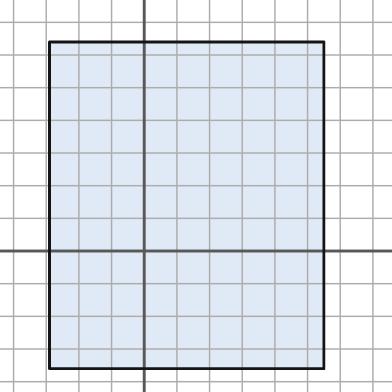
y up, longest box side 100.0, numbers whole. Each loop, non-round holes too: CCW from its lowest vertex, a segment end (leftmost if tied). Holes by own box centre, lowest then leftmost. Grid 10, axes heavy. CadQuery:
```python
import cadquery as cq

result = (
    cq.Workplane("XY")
    .moveTo(-29.0, -36.0)
    .lineTo(55.0, -36.0)
    .lineTo(55.0, 64.0)
    .lineTo(-29.0, 64.0)
    .close()
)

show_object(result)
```